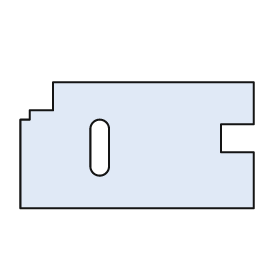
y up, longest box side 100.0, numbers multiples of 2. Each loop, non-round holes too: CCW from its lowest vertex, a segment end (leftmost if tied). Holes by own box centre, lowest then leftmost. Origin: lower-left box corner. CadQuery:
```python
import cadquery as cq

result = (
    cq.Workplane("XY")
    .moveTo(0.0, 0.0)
    .lineTo(100.0, 0.0)
    .lineTo(100.0, 24.0)
    .lineTo(86.0, 24.0)
    .lineTo(86.0, 36.0)
    .lineTo(100.0, 36.0)
    .lineTo(100.0, 54.0)
    .lineTo(14.0, 54.0)
    .lineTo(14.0, 42.0)
    .lineTo(4.0, 42.0)
    .lineTo(4.0, 38.0)
    .lineTo(0.0, 38.0)
    .close()
    .moveTo(30.0, 18.0)
    .threePointArc((34.0, 14.0), (38.0, 18.0))
    .lineTo(38.0, 34.0)
    .threePointArc((34.0, 38.0), (30.0, 34.0))
    .close()
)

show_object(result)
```